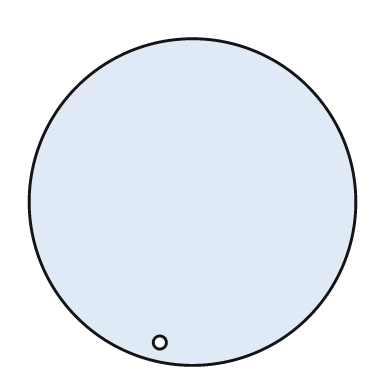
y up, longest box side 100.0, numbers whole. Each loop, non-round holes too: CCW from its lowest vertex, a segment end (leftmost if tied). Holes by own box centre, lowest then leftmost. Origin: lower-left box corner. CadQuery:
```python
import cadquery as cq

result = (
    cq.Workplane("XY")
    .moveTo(50.0, 50.0)
    .circle(50.0)
    .moveTo(40.0, 7.0)
    .circle(2.0)
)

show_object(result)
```